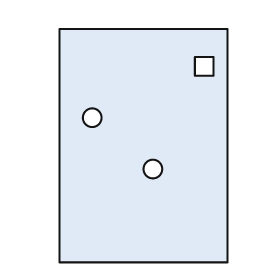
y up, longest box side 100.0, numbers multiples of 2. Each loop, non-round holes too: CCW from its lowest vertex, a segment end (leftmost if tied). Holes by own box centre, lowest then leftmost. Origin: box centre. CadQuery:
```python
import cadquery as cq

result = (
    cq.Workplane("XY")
    .moveTo(-36.0, -50.0)
    .lineTo(36.0, -50.0)
    .lineTo(36.0, 50.0)
    .lineTo(-36.0, 50.0)
    .close()
    .moveTo(4.0, -10.0)
    .circle(4.0)
    .moveTo(-22.0, 12.0)
    .circle(4.0)
    .moveTo(22.0, 30.0)
    .lineTo(30.0, 30.0)
    .lineTo(30.0, 38.0)
    .lineTo(22.0, 38.0)
    .close()
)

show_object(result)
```